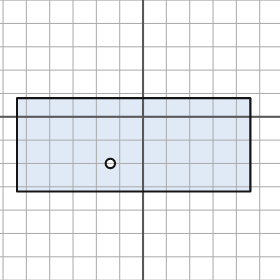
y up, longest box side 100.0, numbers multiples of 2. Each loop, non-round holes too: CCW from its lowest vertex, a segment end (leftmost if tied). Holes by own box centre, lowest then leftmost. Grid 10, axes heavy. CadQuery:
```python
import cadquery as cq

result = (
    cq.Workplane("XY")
    .moveTo(-54.0, -32.0)
    .lineTo(46.0, -32.0)
    .lineTo(46.0, 8.0)
    .lineTo(-54.0, 8.0)
    .close()
    .moveTo(-14.0, -20.0)
    .circle(2.0)
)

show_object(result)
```